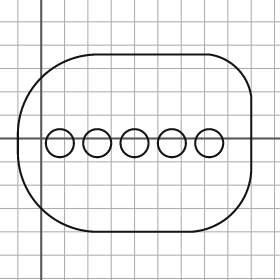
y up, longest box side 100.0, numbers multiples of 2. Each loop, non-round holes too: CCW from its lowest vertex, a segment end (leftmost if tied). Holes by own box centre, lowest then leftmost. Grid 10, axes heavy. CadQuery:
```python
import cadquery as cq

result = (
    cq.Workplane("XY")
    .moveTo(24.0, -40.0)
    .lineTo(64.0, -40.0)
    .threePointArc((82.0, -32.0), (90.0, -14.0))
    .lineTo(90.0, 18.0)
    .threePointArc((84.0, 30.0), (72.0, 36.0))
    .lineTo(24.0, 36.0)
    .threePointArc((0.0, 26.0), (-10.0, 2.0))
    .lineTo(-10.0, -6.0)
    .threePointArc((0.0, -30.0), (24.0, -40.0))
    .close()
    .moveTo(8.0, -2.0)
    .circle(6.0)
    .moveTo(24.0, -2.0)
    .circle(6.0)
    .moveTo(40.0, -2.0)
    .circle(6.0)
    .moveTo(56.0, -2.0)
    .circle(6.0)
    .moveTo(72.0, -2.0)
    .circle(6.0)
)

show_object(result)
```